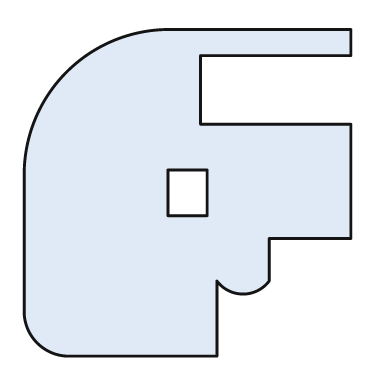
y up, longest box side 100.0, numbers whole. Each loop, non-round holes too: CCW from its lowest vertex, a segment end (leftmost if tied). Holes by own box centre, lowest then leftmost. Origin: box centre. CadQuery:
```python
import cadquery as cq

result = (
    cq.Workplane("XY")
    .moveTo(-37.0, -50.0)
    .lineTo(9.0, -50.0)
    .lineTo(9.0, -27.0)
    .threePointArc((17.0, -31.0), (25.0, -27.0))
    .lineTo(25.0, -14.0)
    .lineTo(50.0, -14.0)
    .lineTo(50.0, 21.0)
    .lineTo(4.0, 21.0)
    .lineTo(4.0, 42.0)
    .lineTo(50.0, 42.0)
    .lineTo(50.0, 50.0)
    .lineTo(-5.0, 50.0)
    .threePointArc((-37.0, 37.0), (-50.0, 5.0))
    .lineTo(-50.0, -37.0)
    .threePointArc((-46.0, -46.0), (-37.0, -50.0))
    .close()
    .moveTo(-6.0, -7.0)
    .lineTo(6.0, -7.0)
    .lineTo(6.0, 7.0)
    .lineTo(-6.0, 7.0)
    .close()
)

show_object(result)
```